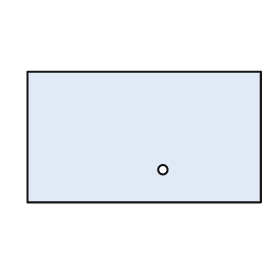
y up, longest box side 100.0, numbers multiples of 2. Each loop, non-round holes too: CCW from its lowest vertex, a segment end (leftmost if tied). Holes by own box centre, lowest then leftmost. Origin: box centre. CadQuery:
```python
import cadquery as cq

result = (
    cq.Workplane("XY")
    .moveTo(-50.0, -28.0)
    .lineTo(50.0, -28.0)
    .lineTo(50.0, 28.0)
    .lineTo(-50.0, 28.0)
    .close()
    .moveTo(8.0, -14.0)
    .circle(2.0)
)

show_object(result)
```